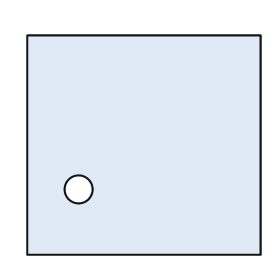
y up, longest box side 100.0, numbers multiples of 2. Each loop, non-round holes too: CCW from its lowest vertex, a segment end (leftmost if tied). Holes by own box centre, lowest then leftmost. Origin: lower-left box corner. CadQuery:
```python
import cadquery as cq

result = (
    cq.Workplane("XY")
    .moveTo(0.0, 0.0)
    .lineTo(100.0, 0.0)
    .lineTo(100.0, 94.0)
    .lineTo(0.0, 94.0)
    .close()
    .moveTo(22.0, 28.0)
    .circle(6.0)
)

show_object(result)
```